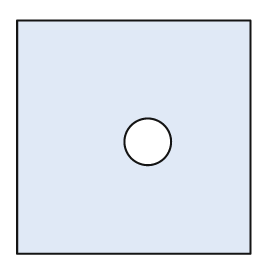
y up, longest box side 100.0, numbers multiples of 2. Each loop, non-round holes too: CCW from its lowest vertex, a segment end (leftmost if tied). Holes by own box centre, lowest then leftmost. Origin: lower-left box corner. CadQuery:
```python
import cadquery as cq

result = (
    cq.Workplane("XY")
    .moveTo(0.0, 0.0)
    .lineTo(100.0, 0.0)
    .lineTo(100.0, 100.0)
    .lineTo(0.0, 100.0)
    .close()
    .moveTo(56.0, 48.0)
    .circle(10.0)
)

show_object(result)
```